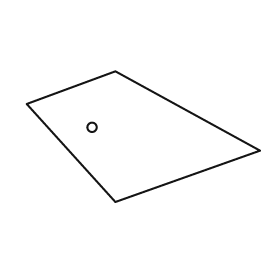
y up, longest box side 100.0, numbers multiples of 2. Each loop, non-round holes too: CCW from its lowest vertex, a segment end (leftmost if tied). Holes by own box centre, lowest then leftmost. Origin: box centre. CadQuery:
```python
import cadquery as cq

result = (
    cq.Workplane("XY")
    .moveTo(-12.0, -28.0)
    .lineTo(50.0, -6.0)
    .lineTo(-12.0, 28.0)
    .lineTo(-50.0, 14.0)
    .close()
    .moveTo(-22.0, 4.0)
    .circle(2.0)
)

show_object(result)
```